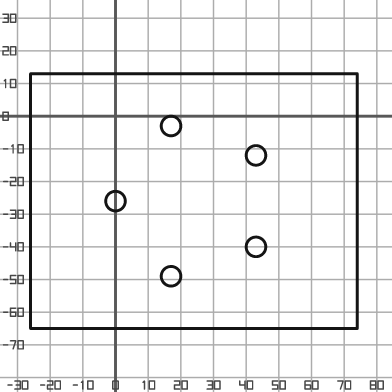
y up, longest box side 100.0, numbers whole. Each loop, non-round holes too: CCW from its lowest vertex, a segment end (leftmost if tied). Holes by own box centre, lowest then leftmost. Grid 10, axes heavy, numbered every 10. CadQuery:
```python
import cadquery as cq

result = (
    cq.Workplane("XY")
    .moveTo(-26.0, -65.0)
    .lineTo(74.0, -65.0)
    .lineTo(74.0, 13.0)
    .lineTo(-26.0, 13.0)
    .close()
    .moveTo(17.0, -49.0)
    .circle(3.0)
    .moveTo(43.0, -40.0)
    .circle(3.0)
    .moveTo(0.0, -26.0)
    .circle(3.0)
    .moveTo(43.0, -12.0)
    .circle(3.0)
    .moveTo(17.0, -3.0)
    .circle(3.0)
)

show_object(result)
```